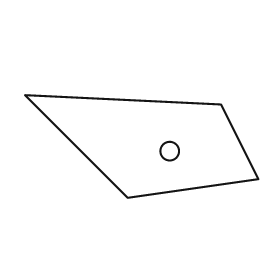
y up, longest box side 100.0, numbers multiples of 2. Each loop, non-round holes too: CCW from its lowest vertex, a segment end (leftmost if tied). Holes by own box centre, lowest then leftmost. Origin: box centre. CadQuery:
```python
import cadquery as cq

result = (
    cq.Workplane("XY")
    .moveTo(-6.0, -22.0)
    .lineTo(50.0, -14.0)
    .lineTo(34.0, 18.0)
    .lineTo(-50.0, 22.0)
    .close()
    .moveTo(12.0, -2.0)
    .circle(4.0)
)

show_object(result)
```